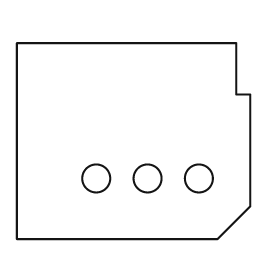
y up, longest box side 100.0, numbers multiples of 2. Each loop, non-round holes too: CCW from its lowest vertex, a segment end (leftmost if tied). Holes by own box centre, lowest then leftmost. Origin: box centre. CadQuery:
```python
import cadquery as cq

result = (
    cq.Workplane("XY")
    .moveTo(-50.0, -42.0)
    .lineTo(36.0, -42.0)
    .lineTo(50.0, -28.0)
    .lineTo(50.0, 20.0)
    .lineTo(44.0, 20.0)
    .lineTo(44.0, 42.0)
    .lineTo(-50.0, 42.0)
    .close()
    .moveTo(-16.0, -16.0)
    .circle(6.0)
    .moveTo(6.0, -16.0)
    .circle(6.0)
    .moveTo(28.0, -16.0)
    .circle(6.0)
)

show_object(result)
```